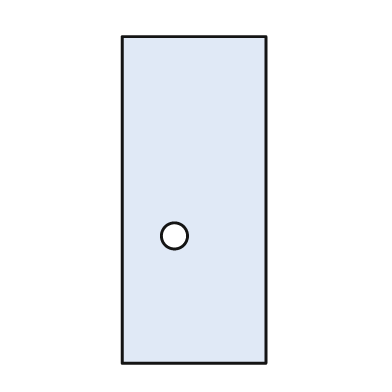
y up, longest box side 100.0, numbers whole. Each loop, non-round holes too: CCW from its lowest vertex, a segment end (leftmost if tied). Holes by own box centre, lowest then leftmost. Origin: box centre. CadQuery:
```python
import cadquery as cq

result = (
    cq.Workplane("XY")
    .moveTo(-22.0, -50.0)
    .lineTo(22.0, -50.0)
    .lineTo(22.0, 50.0)
    .lineTo(-22.0, 50.0)
    .close()
    .moveTo(-6.0, -11.0)
    .circle(4.0)
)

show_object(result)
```